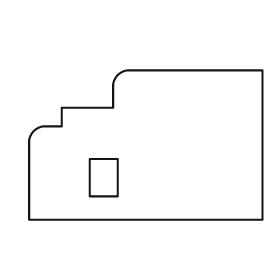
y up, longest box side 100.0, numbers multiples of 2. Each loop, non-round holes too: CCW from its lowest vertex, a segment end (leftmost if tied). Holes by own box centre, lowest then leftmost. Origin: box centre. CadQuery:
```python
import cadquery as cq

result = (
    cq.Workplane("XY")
    .moveTo(-50.0, -32.0)
    .lineTo(50.0, -32.0)
    .lineTo(50.0, 32.0)
    .lineTo(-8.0, 32.0)
    .threePointArc((-12.0, 30.0), (-14.0, 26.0))
    .lineTo(-14.0, 16.0)
    .lineTo(-36.0, 16.0)
    .lineTo(-36.0, 8.0)
    .lineTo(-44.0, 8.0)
    .threePointArc((-48.0, 6.0), (-50.0, 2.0))
    .close()
    .moveTo(-24.0, -22.0)
    .lineTo(-12.0, -22.0)
    .lineTo(-12.0, -6.0)
    .lineTo(-24.0, -6.0)
    .close()
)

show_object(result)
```